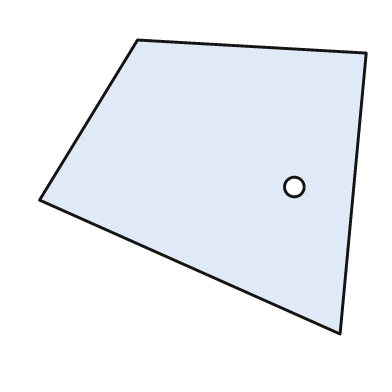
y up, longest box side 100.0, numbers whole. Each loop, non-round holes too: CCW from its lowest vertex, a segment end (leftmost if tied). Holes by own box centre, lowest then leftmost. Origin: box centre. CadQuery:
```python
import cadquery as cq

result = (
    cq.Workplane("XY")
    .moveTo(42.0, -45.0)
    .lineTo(50.0, 41.0)
    .lineTo(-20.0, 45.0)
    .lineTo(-50.0, -4.0)
    .close()
    .moveTo(28.0, 0.0)
    .circle(3.0)
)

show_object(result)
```